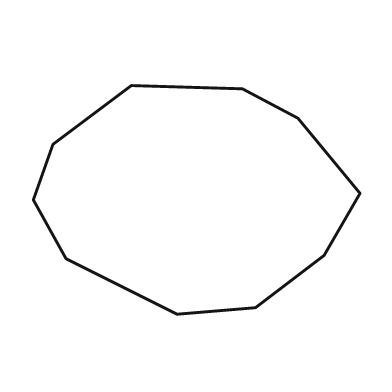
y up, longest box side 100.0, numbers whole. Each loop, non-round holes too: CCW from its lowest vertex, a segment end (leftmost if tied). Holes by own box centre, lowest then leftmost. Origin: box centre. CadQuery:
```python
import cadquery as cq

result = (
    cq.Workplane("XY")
    .moveTo(-6.0, -35.0)
    .lineTo(18.0, -33.0)
    .lineTo(39.0, -17.0)
    .lineTo(50.0, 2.0)
    .lineTo(31.0, 25.0)
    .lineTo(14.0, 34.0)
    .lineTo(-20.0, 35.0)
    .lineTo(-44.0, 17.0)
    .lineTo(-50.0, 0.0)
    .lineTo(-40.0, -18.0)
    .close()
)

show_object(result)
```